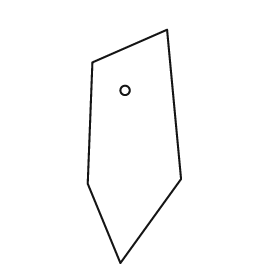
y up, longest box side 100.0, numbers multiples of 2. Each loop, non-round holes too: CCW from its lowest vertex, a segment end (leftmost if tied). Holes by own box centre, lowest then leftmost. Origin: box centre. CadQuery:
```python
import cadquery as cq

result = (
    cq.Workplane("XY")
    .moveTo(-6.0, -50.0)
    .lineTo(20.0, -14.0)
    .lineTo(14.0, 50.0)
    .lineTo(-18.0, 36.0)
    .lineTo(-20.0, -16.0)
    .close()
    .moveTo(-4.0, 24.0)
    .circle(2.0)
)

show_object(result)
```